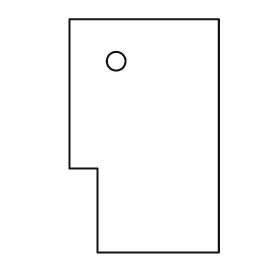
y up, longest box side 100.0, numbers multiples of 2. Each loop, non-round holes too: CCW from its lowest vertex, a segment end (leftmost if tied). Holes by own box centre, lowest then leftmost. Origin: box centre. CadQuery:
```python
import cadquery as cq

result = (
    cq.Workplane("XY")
    .moveTo(-20.0, -50.0)
    .lineTo(32.0, -50.0)
    .lineTo(32.0, 50.0)
    .lineTo(-32.0, 50.0)
    .lineTo(-32.0, -14.0)
    .lineTo(-20.0, -14.0)
    .close()
    .moveTo(-12.0, 32.0)
    .circle(4.0)
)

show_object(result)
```